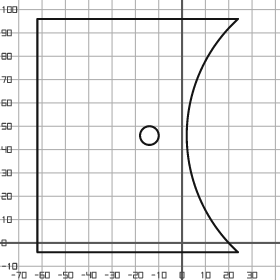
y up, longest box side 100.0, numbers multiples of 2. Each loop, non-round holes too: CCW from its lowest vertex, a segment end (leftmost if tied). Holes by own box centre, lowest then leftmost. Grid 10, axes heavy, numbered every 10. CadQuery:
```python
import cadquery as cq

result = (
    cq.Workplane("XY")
    .moveTo(-62.0, -4.0)
    .lineTo(24.0, -4.0)
    .threePointArc((2.0, 46.0), (24.0, 96.0))
    .lineTo(-62.0, 96.0)
    .close()
    .moveTo(-14.0, 46.0)
    .circle(4.0)
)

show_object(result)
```